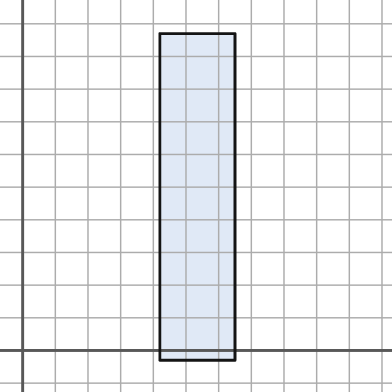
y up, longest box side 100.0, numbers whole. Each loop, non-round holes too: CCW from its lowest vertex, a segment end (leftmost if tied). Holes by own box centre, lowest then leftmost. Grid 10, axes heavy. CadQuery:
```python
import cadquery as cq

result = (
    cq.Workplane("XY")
    .moveTo(42.0, -3.0)
    .lineTo(65.0, -3.0)
    .lineTo(65.0, 97.0)
    .lineTo(42.0, 97.0)
    .close()
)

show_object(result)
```